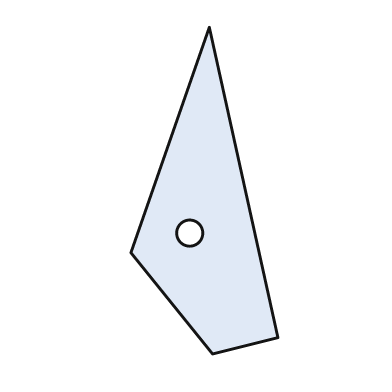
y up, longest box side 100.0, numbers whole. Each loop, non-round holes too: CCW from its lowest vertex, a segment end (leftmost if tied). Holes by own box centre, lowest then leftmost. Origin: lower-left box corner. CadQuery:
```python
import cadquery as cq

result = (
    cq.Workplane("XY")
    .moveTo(25.0, 0.0)
    .lineTo(45.0, 5.0)
    .lineTo(24.0, 100.0)
    .lineTo(0.0, 31.0)
    .close()
    .moveTo(18.0, 37.0)
    .circle(4.0)
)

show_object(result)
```